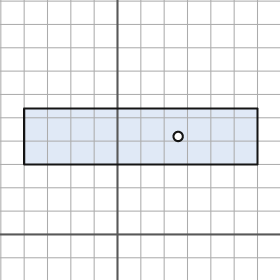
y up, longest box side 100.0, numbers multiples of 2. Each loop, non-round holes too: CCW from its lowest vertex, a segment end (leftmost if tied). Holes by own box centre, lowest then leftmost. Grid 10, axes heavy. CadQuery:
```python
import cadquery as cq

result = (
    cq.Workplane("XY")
    .moveTo(-40.0, 30.0)
    .lineTo(60.0, 30.0)
    .lineTo(60.0, 54.0)
    .lineTo(-40.0, 54.0)
    .close()
    .moveTo(26.0, 42.0)
    .circle(2.0)
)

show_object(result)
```